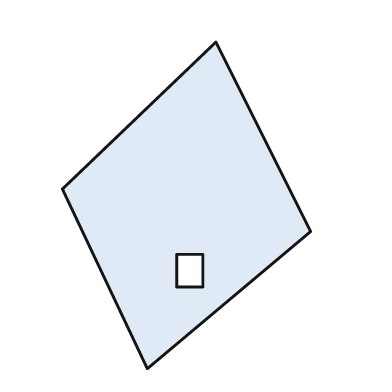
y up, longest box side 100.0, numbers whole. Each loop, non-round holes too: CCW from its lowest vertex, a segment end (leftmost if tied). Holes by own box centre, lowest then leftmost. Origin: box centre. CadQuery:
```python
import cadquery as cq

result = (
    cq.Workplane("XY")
    .moveTo(-12.0, -50.0)
    .lineTo(38.0, -8.0)
    .lineTo(9.0, 50.0)
    .lineTo(-38.0, 5.0)
    .close()
    .moveTo(-3.0, -25.0)
    .lineTo(5.0, -25.0)
    .lineTo(5.0, -15.0)
    .lineTo(-3.0, -15.0)
    .close()
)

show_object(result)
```